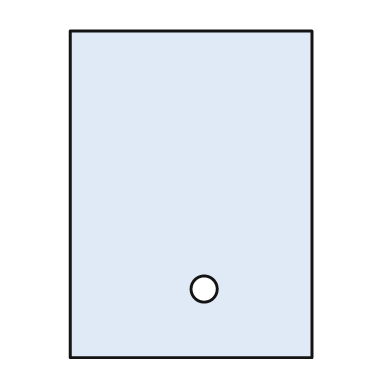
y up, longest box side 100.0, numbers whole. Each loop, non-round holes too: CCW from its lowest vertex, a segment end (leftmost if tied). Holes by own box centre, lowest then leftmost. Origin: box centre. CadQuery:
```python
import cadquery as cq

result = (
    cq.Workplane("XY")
    .moveTo(-37.0, -50.0)
    .lineTo(37.0, -50.0)
    .lineTo(37.0, 50.0)
    .lineTo(-37.0, 50.0)
    .close()
    .moveTo(4.0, -29.0)
    .circle(4.0)
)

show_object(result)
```